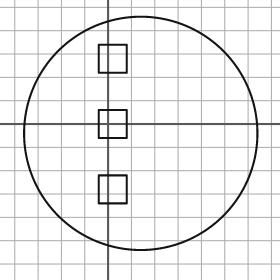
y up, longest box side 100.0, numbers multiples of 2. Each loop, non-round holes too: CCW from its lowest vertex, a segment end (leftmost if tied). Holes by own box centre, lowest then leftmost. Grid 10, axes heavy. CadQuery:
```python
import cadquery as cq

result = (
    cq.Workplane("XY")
    .moveTo(14.0, -4.0)
    .circle(50.0)
    .moveTo(-4.0, -34.0)
    .lineTo(8.0, -34.0)
    .lineTo(8.0, -22.0)
    .lineTo(-4.0, -22.0)
    .close()
    .moveTo(-4.0, -6.0)
    .lineTo(8.0, -6.0)
    .lineTo(8.0, 6.0)
    .lineTo(-4.0, 6.0)
    .close()
    .moveTo(-4.0, 22.0)
    .lineTo(8.0, 22.0)
    .lineTo(8.0, 34.0)
    .lineTo(-4.0, 34.0)
    .close()
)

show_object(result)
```